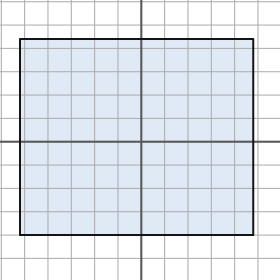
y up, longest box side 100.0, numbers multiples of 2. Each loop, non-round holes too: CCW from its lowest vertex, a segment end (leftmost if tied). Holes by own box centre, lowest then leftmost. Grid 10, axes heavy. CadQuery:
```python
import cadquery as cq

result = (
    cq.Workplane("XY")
    .moveTo(-52.0, -40.0)
    .lineTo(48.0, -40.0)
    .lineTo(48.0, 44.0)
    .lineTo(-52.0, 44.0)
    .close()
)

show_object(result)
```